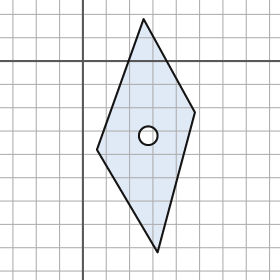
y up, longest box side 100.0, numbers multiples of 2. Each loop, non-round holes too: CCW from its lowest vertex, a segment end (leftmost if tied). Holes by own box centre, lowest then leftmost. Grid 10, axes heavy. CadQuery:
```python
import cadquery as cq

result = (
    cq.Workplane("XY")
    .moveTo(32.0, -82.0)
    .lineTo(48.0, -22.0)
    .lineTo(26.0, 18.0)
    .lineTo(6.0, -38.0)
    .close()
    .moveTo(28.0, -32.0)
    .circle(4.0)
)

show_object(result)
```